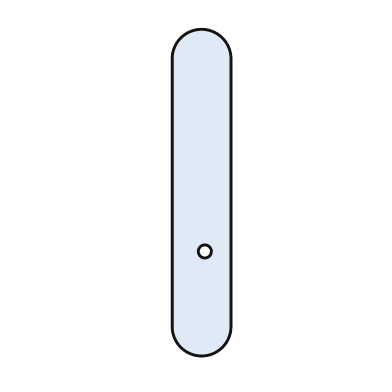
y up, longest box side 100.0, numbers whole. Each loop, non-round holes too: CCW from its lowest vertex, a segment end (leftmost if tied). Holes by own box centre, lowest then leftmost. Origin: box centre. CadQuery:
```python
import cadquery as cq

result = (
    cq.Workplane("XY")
    .moveTo(-9.0, -41.0)
    .threePointArc((0.0, -50.0), (9.0, -41.0))
    .lineTo(9.0, 41.0)
    .threePointArc((0.0, 50.0), (-9.0, 41.0))
    .close()
    .moveTo(1.0, -18.0)
    .circle(2.0)
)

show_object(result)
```